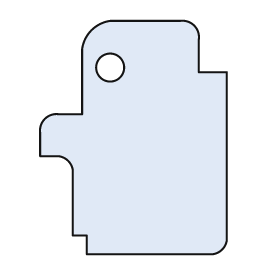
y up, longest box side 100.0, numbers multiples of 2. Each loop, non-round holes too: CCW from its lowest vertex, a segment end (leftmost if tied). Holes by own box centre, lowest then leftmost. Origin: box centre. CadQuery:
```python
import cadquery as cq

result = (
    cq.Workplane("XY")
    .moveTo(-20.0, -50.0)
    .lineTo(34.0, -50.0)
    .threePointArc((38.0, -48.0), (40.0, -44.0))
    .lineTo(40.0, 28.0)
    .lineTo(28.0, 28.0)
    .lineTo(28.0, 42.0)
    .threePointArc((26.0, 48.0), (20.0, 50.0))
    .lineTo(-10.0, 50.0)
    .threePointArc((-18.0, 46.0), (-22.0, 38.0))
    .lineTo(-22.0, 10.0)
    .lineTo(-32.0, 10.0)
    .threePointArc((-38.0, 8.0), (-40.0, 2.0))
    .lineTo(-40.0, -8.0)
    .lineTo(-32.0, -8.0)
    .threePointArc((-28.0, -10.0), (-26.0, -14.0))
    .lineTo(-26.0, -42.0)
    .lineTo(-20.0, -42.0)
    .close()
    .moveTo(-10.0, 30.0)
    .circle(6.0)
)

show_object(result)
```